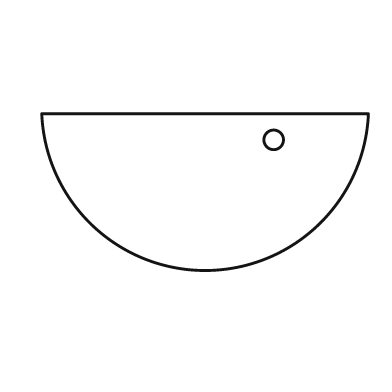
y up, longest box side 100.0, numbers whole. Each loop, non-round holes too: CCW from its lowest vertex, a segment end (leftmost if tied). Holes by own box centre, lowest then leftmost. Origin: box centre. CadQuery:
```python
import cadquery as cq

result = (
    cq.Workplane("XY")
    .moveTo(-50.0, 24.0)
    .threePointArc((0.0, -24.0), (50.0, 24.0))
    .close()
    .moveTo(21.0, 16.0)
    .circle(3.0)
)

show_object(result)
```